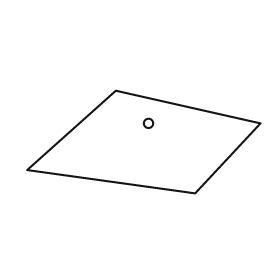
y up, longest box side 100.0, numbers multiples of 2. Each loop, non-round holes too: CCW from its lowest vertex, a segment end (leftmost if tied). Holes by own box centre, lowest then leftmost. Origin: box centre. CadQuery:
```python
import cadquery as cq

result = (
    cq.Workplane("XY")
    .moveTo(22.0, -22.0)
    .lineTo(50.0, 8.0)
    .lineTo(-12.0, 22.0)
    .lineTo(-50.0, -12.0)
    .close()
    .moveTo(2.0, 8.0)
    .circle(2.0)
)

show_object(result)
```